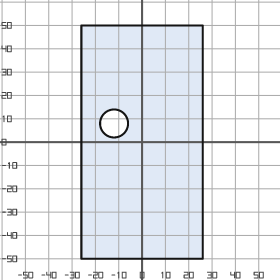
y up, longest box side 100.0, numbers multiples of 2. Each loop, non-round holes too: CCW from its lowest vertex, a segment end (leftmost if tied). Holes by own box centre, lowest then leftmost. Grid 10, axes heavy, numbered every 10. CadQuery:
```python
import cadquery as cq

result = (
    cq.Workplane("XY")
    .moveTo(-26.0, -50.0)
    .lineTo(26.0, -50.0)
    .lineTo(26.0, 50.0)
    .lineTo(-26.0, 50.0)
    .close()
    .moveTo(-12.0, 8.0)
    .circle(6.0)
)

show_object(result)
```